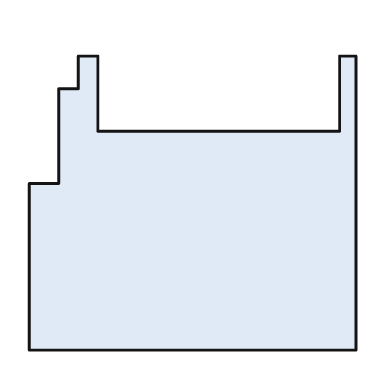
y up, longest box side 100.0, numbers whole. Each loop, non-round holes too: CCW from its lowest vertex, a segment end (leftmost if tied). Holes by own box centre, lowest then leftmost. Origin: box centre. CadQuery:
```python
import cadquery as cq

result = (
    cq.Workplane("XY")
    .moveTo(-50.0, -45.0)
    .lineTo(50.0, -45.0)
    .lineTo(50.0, 45.0)
    .lineTo(45.0, 45.0)
    .lineTo(45.0, 22.0)
    .lineTo(-29.0, 22.0)
    .lineTo(-29.0, 45.0)
    .lineTo(-35.0, 45.0)
    .lineTo(-35.0, 35.0)
    .lineTo(-41.0, 35.0)
    .lineTo(-41.0, 6.0)
    .lineTo(-50.0, 6.0)
    .close()
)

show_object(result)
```